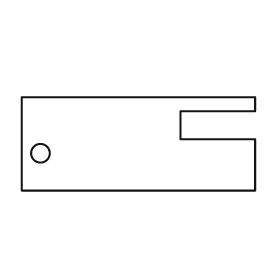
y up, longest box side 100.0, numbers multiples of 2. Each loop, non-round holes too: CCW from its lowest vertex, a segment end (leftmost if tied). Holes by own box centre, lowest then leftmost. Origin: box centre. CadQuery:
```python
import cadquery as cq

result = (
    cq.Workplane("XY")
    .moveTo(-50.0, -20.0)
    .lineTo(50.0, -20.0)
    .lineTo(50.0, 2.0)
    .lineTo(18.0, 2.0)
    .lineTo(18.0, 14.0)
    .lineTo(50.0, 14.0)
    .lineTo(50.0, 20.0)
    .lineTo(-50.0, 20.0)
    .close()
    .moveTo(-42.0, -4.0)
    .circle(4.0)
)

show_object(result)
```